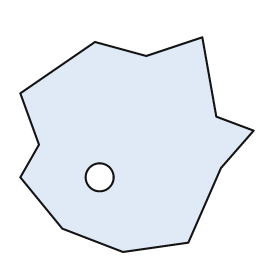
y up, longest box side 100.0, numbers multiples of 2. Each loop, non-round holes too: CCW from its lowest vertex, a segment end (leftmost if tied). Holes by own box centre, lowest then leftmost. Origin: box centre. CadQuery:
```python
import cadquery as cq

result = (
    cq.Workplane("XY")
    .moveTo(-6.0, -46.0)
    .lineTo(22.0, -42.0)
    .lineTo(36.0, -10.0)
    .lineTo(50.0, 6.0)
    .lineTo(34.0, 12.0)
    .lineTo(28.0, 46.0)
    .lineTo(4.0, 38.0)
    .lineTo(-18.0, 44.0)
    .lineTo(-50.0, 22.0)
    .lineTo(-42.0, 0.0)
    .lineTo(-50.0, -14.0)
    .lineTo(-32.0, -36.0)
    .close()
    .moveTo(-16.0, -14.0)
    .circle(6.0)
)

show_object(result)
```